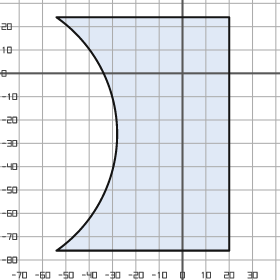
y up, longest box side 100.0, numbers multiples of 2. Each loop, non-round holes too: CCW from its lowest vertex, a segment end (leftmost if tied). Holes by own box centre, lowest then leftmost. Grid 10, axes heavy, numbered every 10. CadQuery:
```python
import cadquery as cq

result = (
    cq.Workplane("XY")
    .moveTo(-54.0, -76.0)
    .lineTo(20.0, -76.0)
    .lineTo(20.0, 24.0)
    .lineTo(-54.0, 24.0)
    .threePointArc((-28.0, -26.0), (-54.0, -76.0))
    .close()
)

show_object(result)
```